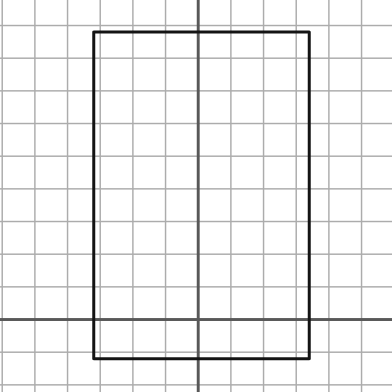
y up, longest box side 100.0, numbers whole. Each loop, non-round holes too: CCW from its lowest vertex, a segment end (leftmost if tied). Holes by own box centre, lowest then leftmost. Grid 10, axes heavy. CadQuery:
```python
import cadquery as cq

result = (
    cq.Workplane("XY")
    .moveTo(-32.0, -12.0)
    .lineTo(34.0, -12.0)
    .lineTo(34.0, 88.0)
    .lineTo(-32.0, 88.0)
    .close()
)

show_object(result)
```